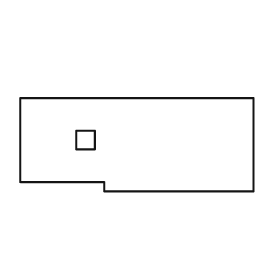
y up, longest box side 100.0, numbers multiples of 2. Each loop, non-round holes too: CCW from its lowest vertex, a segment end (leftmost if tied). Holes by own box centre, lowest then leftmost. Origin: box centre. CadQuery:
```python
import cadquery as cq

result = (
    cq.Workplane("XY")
    .moveTo(-14.0, -20.0)
    .lineTo(50.0, -20.0)
    .lineTo(50.0, 20.0)
    .lineTo(-50.0, 20.0)
    .lineTo(-50.0, -16.0)
    .lineTo(-14.0, -16.0)
    .close()
    .moveTo(-26.0, -2.0)
    .lineTo(-18.0, -2.0)
    .lineTo(-18.0, 6.0)
    .lineTo(-26.0, 6.0)
    .close()
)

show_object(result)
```